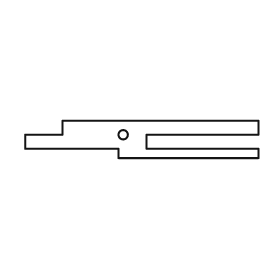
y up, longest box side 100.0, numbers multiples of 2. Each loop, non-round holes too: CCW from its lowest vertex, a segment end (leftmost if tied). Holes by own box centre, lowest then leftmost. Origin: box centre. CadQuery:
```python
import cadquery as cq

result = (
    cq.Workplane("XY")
    .moveTo(-10.0, -8.0)
    .lineTo(50.0, -8.0)
    .lineTo(50.0, -4.0)
    .lineTo(2.0, -4.0)
    .lineTo(2.0, 2.0)
    .lineTo(50.0, 2.0)
    .lineTo(50.0, 8.0)
    .lineTo(-34.0, 8.0)
    .lineTo(-34.0, 2.0)
    .lineTo(-50.0, 2.0)
    .lineTo(-50.0, -4.0)
    .lineTo(-10.0, -4.0)
    .close()
    .moveTo(-8.0, 2.0)
    .circle(2.0)
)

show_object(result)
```